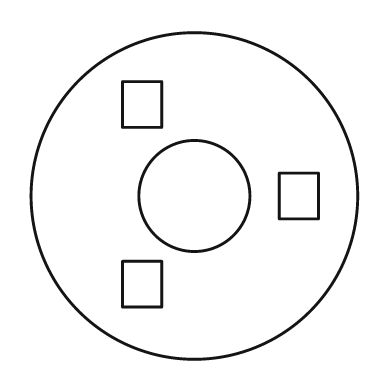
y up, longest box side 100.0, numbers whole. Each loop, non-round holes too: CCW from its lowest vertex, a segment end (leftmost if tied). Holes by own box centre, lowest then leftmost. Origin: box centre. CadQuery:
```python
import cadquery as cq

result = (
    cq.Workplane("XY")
    .moveTo(0.0, 0.0)
    .circle(50.0)
    .moveTo(-22.0, -34.0)
    .lineTo(-10.0, -34.0)
    .lineTo(-10.0, -20.0)
    .lineTo(-22.0, -20.0)
    .close()
    .moveTo(0.0, 0.0)
    .circle(17.0)
    .moveTo(26.0, -7.0)
    .lineTo(38.0, -7.0)
    .lineTo(38.0, 7.0)
    .lineTo(26.0, 7.0)
    .close()
    .moveTo(-22.0, 21.0)
    .lineTo(-10.0, 21.0)
    .lineTo(-10.0, 35.0)
    .lineTo(-22.0, 35.0)
    .close()
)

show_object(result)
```